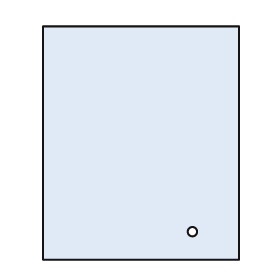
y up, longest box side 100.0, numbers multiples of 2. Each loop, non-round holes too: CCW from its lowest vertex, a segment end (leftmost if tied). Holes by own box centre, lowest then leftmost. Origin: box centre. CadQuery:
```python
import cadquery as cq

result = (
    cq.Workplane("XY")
    .moveTo(-42.0, -50.0)
    .lineTo(42.0, -50.0)
    .lineTo(42.0, 50.0)
    .lineTo(-42.0, 50.0)
    .close()
    .moveTo(22.0, -38.0)
    .circle(2.0)
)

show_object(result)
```